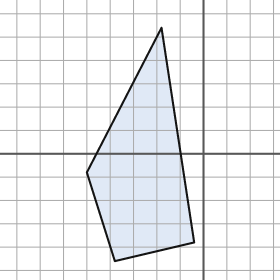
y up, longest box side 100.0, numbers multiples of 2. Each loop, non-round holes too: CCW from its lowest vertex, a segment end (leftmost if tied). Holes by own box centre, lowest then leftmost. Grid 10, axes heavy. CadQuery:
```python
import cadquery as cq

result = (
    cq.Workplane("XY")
    .moveTo(-38.0, -46.0)
    .lineTo(-4.0, -38.0)
    .lineTo(-18.0, 54.0)
    .lineTo(-50.0, -8.0)
    .close()
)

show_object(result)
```